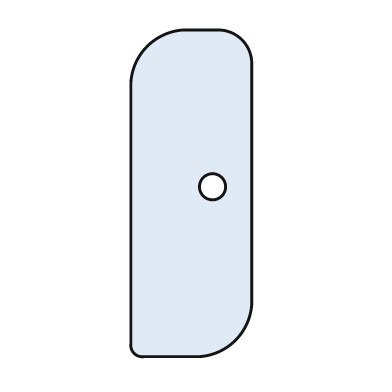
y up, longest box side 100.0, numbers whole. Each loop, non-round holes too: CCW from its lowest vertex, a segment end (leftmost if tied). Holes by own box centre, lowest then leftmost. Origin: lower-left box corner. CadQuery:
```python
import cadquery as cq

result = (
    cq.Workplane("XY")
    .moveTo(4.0, 0.0)
    .lineTo(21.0, 0.0)
    .threePointArc((32.0, 5.0), (37.0, 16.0))
    .lineTo(37.0, 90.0)
    .threePointArc((34.0, 97.0), (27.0, 100.0))
    .lineTo(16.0, 100.0)
    .threePointArc((5.0, 95.0), (0.0, 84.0))
    .lineTo(0.0, 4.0)
    .threePointArc((1.0, 1.0), (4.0, 0.0))
    .close()
    .moveTo(25.0, 52.0)
    .circle(4.0)
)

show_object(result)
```